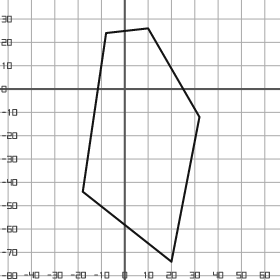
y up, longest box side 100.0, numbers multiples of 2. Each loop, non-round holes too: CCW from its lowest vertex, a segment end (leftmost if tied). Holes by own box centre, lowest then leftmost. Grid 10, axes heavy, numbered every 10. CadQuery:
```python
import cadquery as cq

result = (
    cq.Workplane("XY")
    .moveTo(20.0, -74.0)
    .lineTo(32.0, -12.0)
    .lineTo(10.0, 26.0)
    .lineTo(-8.0, 24.0)
    .lineTo(-18.0, -44.0)
    .close()
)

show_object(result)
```